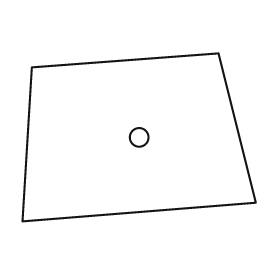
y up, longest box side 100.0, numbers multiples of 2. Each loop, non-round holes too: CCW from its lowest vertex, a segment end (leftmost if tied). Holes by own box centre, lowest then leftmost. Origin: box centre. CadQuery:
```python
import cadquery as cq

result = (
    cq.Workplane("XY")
    .moveTo(-50.0, -36.0)
    .lineTo(50.0, -28.0)
    .lineTo(34.0, 36.0)
    .lineTo(-46.0, 30.0)
    .close()
    .moveTo(0.0, 0.0)
    .circle(4.0)
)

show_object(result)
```